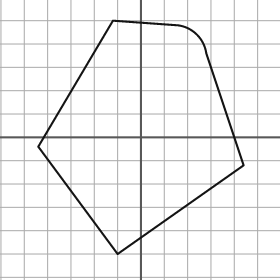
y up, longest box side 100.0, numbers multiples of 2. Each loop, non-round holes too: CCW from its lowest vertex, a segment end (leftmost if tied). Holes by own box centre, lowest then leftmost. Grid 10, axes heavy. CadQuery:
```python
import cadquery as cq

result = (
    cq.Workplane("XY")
    .moveTo(-10.0, -50.0)
    .lineTo(44.0, -12.0)
    .lineTo(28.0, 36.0)
    .threePointArc((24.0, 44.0), (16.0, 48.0))
    .lineTo(-12.0, 50.0)
    .lineTo(-44.0, -4.0)
    .close()
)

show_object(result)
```